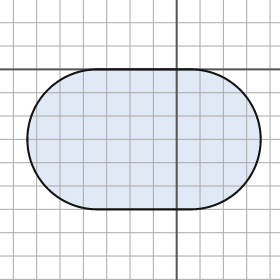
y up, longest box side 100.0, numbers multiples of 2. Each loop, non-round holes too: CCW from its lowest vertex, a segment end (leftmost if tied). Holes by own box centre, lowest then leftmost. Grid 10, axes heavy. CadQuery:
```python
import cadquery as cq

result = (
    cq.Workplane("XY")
    .moveTo(-34.0, -60.0)
    .lineTo(6.0, -60.0)
    .threePointArc((36.0, -30.0), (6.0, 0.0))
    .lineTo(-34.0, 0.0)
    .threePointArc((-64.0, -30.0), (-34.0, -60.0))
    .close()
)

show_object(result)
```